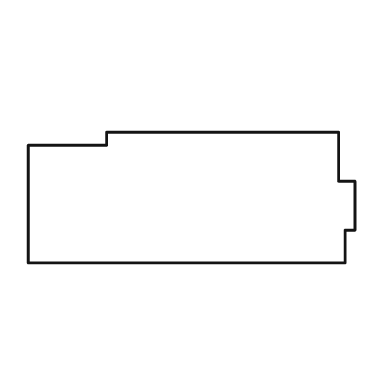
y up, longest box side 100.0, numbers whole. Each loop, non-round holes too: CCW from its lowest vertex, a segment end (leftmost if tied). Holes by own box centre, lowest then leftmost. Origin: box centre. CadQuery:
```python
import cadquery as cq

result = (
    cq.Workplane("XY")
    .moveTo(-50.0, -20.0)
    .lineTo(47.0, -20.0)
    .lineTo(47.0, -10.0)
    .lineTo(50.0, -10.0)
    .lineTo(50.0, 5.0)
    .lineTo(45.0, 5.0)
    .lineTo(45.0, 20.0)
    .lineTo(-26.0, 20.0)
    .lineTo(-26.0, 16.0)
    .lineTo(-50.0, 16.0)
    .close()
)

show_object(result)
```